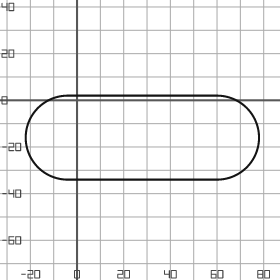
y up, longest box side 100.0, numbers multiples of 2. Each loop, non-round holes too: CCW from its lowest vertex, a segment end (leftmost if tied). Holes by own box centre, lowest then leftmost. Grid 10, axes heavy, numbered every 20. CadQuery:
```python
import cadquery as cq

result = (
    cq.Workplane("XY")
    .moveTo(-4.0, -34.0)
    .lineTo(60.0, -34.0)
    .threePointArc((78.0, -16.0), (60.0, 2.0))
    .lineTo(-4.0, 2.0)
    .threePointArc((-22.0, -16.0), (-4.0, -34.0))
    .close()
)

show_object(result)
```